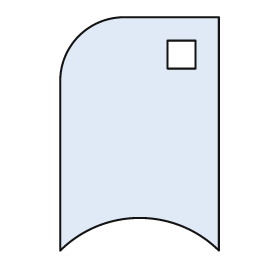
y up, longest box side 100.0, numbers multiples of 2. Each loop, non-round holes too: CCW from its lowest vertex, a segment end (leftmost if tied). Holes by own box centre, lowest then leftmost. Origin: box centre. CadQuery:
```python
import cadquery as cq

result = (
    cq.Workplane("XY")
    .moveTo(-34.0, -50.0)
    .threePointArc((0.0, -36.0), (34.0, -50.0))
    .lineTo(34.0, 50.0)
    .lineTo(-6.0, 50.0)
    .threePointArc((-26.0, 42.0), (-34.0, 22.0))
    .close()
    .moveTo(12.0, 28.0)
    .lineTo(24.0, 28.0)
    .lineTo(24.0, 40.0)
    .lineTo(12.0, 40.0)
    .close()
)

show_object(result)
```